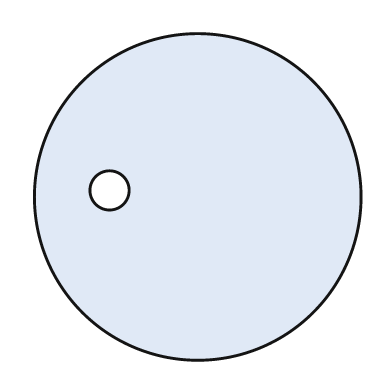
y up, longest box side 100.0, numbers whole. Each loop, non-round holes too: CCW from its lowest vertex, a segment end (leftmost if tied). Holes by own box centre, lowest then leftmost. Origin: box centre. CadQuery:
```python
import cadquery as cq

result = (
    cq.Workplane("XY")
    .moveTo(0.0, 0.0)
    .circle(50.0)
    .moveTo(-27.0, 2.0)
    .circle(6.0)
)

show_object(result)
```